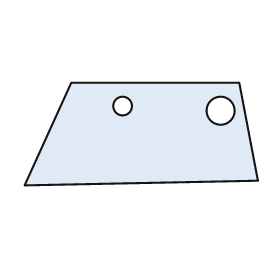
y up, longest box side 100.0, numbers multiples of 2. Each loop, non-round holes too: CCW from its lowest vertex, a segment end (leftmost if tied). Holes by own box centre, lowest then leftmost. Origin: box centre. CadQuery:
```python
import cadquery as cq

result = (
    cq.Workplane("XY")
    .moveTo(-50.0, -22.0)
    .lineTo(50.0, -20.0)
    .lineTo(42.0, 22.0)
    .lineTo(-30.0, 22.0)
    .close()
    .moveTo(34.0, 10.0)
    .circle(6.0)
    .moveTo(-8.0, 12.0)
    .circle(4.0)
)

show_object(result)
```